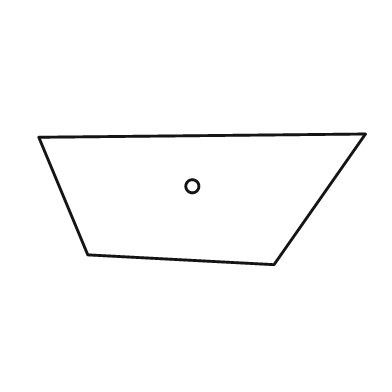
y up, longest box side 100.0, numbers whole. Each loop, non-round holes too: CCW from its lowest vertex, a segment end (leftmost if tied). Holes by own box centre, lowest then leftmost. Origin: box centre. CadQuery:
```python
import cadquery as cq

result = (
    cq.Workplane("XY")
    .moveTo(22.0, -20.0)
    .lineTo(50.0, 20.0)
    .lineTo(-50.0, 19.0)
    .lineTo(-35.0, -17.0)
    .close()
    .moveTo(-3.0, 4.0)
    .circle(2.0)
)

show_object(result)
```